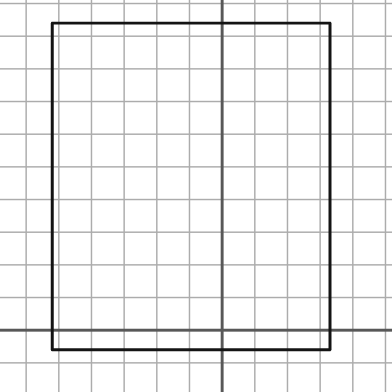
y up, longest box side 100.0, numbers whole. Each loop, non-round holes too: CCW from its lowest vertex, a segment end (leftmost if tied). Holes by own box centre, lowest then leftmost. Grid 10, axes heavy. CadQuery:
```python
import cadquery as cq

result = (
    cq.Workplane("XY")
    .moveTo(-52.0, -6.0)
    .lineTo(33.0, -6.0)
    .lineTo(33.0, 94.0)
    .lineTo(-52.0, 94.0)
    .close()
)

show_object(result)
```